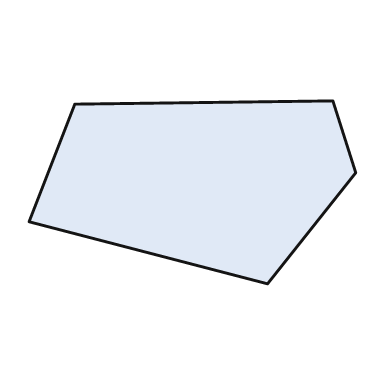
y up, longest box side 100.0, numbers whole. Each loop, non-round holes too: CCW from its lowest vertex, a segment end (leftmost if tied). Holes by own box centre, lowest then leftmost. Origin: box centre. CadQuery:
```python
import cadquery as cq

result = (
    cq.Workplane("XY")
    .moveTo(23.0, -28.0)
    .lineTo(50.0, 6.0)
    .lineTo(43.0, 28.0)
    .lineTo(-36.0, 27.0)
    .lineTo(-50.0, -9.0)
    .close()
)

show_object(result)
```